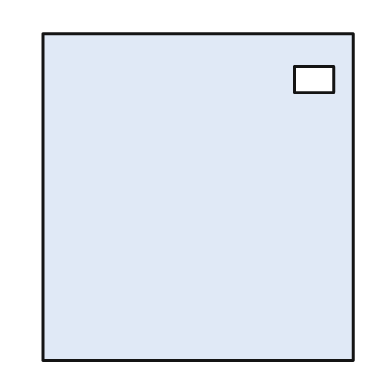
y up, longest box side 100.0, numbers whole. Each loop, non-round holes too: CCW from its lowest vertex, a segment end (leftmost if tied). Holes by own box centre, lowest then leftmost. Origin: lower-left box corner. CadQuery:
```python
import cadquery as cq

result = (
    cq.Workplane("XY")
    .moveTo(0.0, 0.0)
    .lineTo(95.0, 0.0)
    .lineTo(95.0, 100.0)
    .lineTo(0.0, 100.0)
    .close()
    .moveTo(77.0, 82.0)
    .lineTo(89.0, 82.0)
    .lineTo(89.0, 90.0)
    .lineTo(77.0, 90.0)
    .close()
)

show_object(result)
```